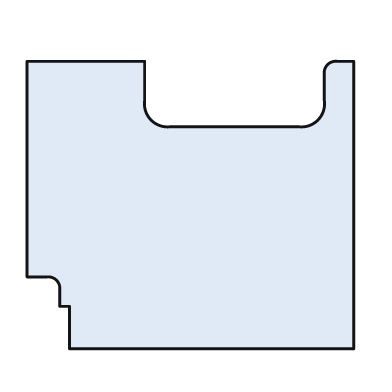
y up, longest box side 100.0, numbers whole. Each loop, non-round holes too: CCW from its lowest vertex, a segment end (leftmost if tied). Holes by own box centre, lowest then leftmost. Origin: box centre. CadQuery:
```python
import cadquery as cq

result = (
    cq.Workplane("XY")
    .moveTo(-37.0, -44.0)
    .lineTo(50.0, -44.0)
    .lineTo(50.0, 44.0)
    .lineTo(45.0, 44.0)
    .threePointArc((42.0, 43.0), (41.0, 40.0))
    .lineTo(41.0, 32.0)
    .threePointArc((39.0, 26.0), (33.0, 24.0))
    .lineTo(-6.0, 24.0)
    .threePointArc((-12.0, 26.0), (-14.0, 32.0))
    .lineTo(-14.0, 44.0)
    .lineTo(-50.0, 44.0)
    .lineTo(-50.0, -22.0)
    .lineTo(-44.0, -22.0)
    .threePointArc((-41.0, -23.0), (-40.0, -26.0))
    .lineTo(-40.0, -31.0)
    .lineTo(-37.0, -31.0)
    .close()
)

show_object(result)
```